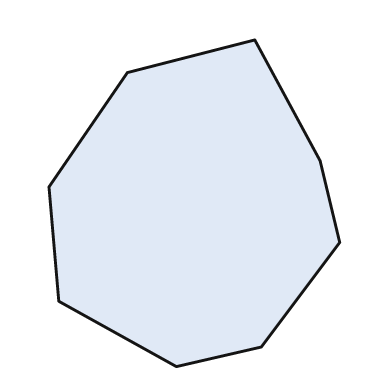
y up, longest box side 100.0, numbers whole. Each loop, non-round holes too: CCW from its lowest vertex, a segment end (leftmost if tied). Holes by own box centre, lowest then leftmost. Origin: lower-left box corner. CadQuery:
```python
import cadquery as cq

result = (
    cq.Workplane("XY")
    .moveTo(39.0, 0.0)
    .lineTo(65.0, 6.0)
    .lineTo(89.0, 38.0)
    .lineTo(83.0, 63.0)
    .lineTo(63.0, 100.0)
    .lineTo(24.0, 90.0)
    .lineTo(0.0, 55.0)
    .lineTo(3.0, 20.0)
    .close()
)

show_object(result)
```